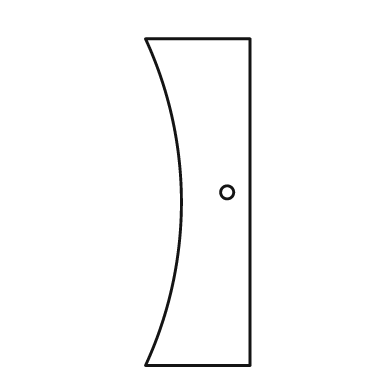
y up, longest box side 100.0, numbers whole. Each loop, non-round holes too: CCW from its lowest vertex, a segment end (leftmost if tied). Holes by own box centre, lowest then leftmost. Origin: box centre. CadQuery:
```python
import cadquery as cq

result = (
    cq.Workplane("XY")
    .moveTo(-16.0, -50.0)
    .lineTo(16.0, -50.0)
    .lineTo(16.0, 50.0)
    .lineTo(-16.0, 50.0)
    .threePointArc((-5.0, 0.0), (-16.0, -50.0))
    .close()
    .moveTo(9.0, 3.0)
    .circle(2.0)
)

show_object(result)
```